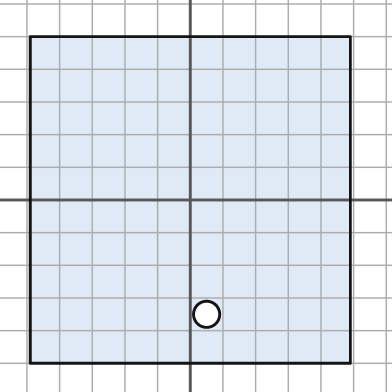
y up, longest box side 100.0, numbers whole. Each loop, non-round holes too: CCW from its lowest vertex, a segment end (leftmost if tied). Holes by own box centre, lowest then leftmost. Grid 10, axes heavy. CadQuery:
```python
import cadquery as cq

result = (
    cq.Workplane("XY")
    .moveTo(-49.0, -50.0)
    .lineTo(49.0, -50.0)
    .lineTo(49.0, 50.0)
    .lineTo(-49.0, 50.0)
    .close()
    .moveTo(5.0, -35.0)
    .circle(4.0)
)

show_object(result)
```